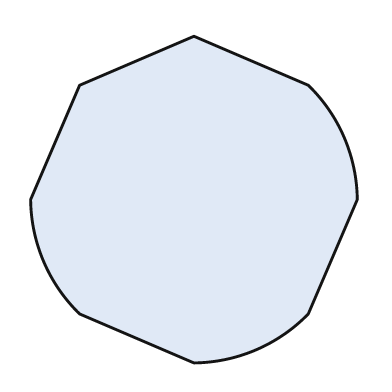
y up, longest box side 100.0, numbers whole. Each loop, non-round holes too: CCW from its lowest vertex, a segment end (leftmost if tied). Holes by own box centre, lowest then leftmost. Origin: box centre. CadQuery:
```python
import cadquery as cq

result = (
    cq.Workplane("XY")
    .moveTo(0.0, -50.0)
    .threePointArc((19.0, -46.0), (35.0, -35.0))
    .lineTo(50.0, 0.0)
    .threePointArc((46.0, 19.0), (35.0, 35.0))
    .lineTo(0.0, 50.0)
    .lineTo(-35.0, 35.0)
    .lineTo(-50.0, 0.0)
    .threePointArc((-46.0, -19.0), (-35.0, -35.0))
    .close()
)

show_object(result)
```